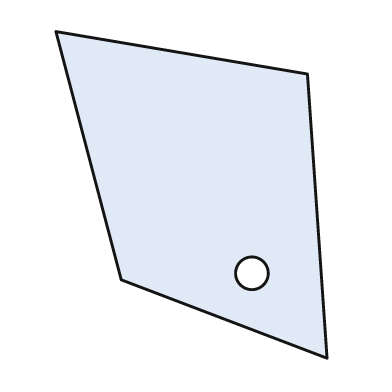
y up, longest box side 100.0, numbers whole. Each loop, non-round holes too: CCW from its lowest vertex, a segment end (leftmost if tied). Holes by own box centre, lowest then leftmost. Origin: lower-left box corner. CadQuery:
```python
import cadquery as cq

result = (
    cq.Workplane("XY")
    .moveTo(83.0, 0.0)
    .lineTo(77.0, 87.0)
    .lineTo(0.0, 100.0)
    .lineTo(20.0, 24.0)
    .close()
    .moveTo(60.0, 26.0)
    .circle(5.0)
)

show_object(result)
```